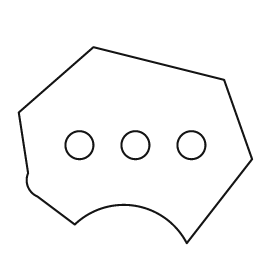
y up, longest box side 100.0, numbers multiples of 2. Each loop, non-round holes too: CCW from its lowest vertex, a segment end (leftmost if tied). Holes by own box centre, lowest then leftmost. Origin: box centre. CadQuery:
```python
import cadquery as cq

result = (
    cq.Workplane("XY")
    .moveTo(22.0, -42.0)
    .lineTo(50.0, -6.0)
    .lineTo(38.0, 28.0)
    .lineTo(-18.0, 42.0)
    .lineTo(-50.0, 14.0)
    .lineTo(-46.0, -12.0)
    .threePointArc((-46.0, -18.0), (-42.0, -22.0))
    .lineTo(-26.0, -34.0)
    .threePointArc((0.0, -26.0), (22.0, -42.0))
    .close()
    .moveTo(-24.0, 0.0)
    .circle(6.0)
    .moveTo(0.0, 0.0)
    .circle(6.0)
    .moveTo(24.0, 0.0)
    .circle(6.0)
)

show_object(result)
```